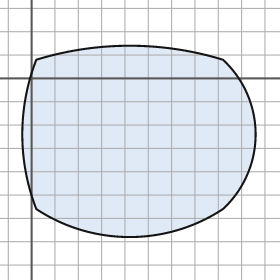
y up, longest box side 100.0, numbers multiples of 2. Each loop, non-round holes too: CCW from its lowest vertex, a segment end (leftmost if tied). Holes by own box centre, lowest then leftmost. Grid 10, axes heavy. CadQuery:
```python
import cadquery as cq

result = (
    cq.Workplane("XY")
    .moveTo(2.0, -56.0)
    .threePointArc((42.0, -68.0), (82.0, -56.0))
    .threePointArc((96.0, -24.0), (82.0, 8.0))
    .threePointArc((42.0, 14.0), (2.0, 8.0))
    .threePointArc((-4.0, -24.0), (2.0, -56.0))
    .close()
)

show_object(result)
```